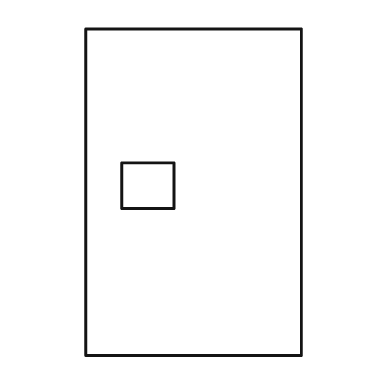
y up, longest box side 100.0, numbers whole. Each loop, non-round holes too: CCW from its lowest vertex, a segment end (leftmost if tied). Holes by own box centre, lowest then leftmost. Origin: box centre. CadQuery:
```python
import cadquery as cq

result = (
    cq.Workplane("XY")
    .moveTo(-33.0, -50.0)
    .lineTo(33.0, -50.0)
    .lineTo(33.0, 50.0)
    .lineTo(-33.0, 50.0)
    .close()
    .moveTo(-22.0, -5.0)
    .lineTo(-6.0, -5.0)
    .lineTo(-6.0, 9.0)
    .lineTo(-22.0, 9.0)
    .close()
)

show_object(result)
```